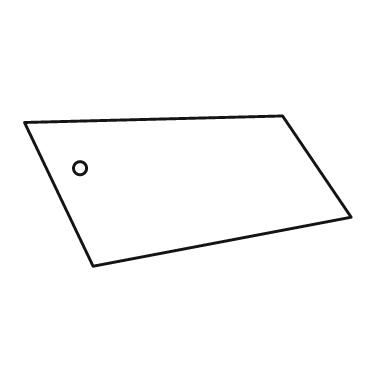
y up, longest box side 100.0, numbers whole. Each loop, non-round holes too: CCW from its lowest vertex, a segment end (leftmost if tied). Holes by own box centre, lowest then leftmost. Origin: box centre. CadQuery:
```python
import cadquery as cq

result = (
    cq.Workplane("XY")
    .moveTo(-29.0, -23.0)
    .lineTo(50.0, -8.0)
    .lineTo(29.0, 23.0)
    .lineTo(-50.0, 21.0)
    .close()
    .moveTo(-33.0, 7.0)
    .circle(2.0)
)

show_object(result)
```